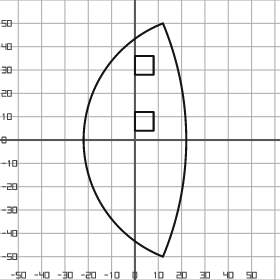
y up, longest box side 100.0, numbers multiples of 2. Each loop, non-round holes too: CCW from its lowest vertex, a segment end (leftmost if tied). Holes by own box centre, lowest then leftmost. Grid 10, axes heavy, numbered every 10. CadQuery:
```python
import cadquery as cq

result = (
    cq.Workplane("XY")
    .moveTo(12.0, -50.0)
    .threePointArc((22.0, 0.0), (12.0, 50.0))
    .threePointArc((-22.0, 0.0), (12.0, -50.0))
    .close()
    .moveTo(0.0, 4.0)
    .lineTo(8.0, 4.0)
    .lineTo(8.0, 12.0)
    .lineTo(0.0, 12.0)
    .close()
    .moveTo(0.0, 28.0)
    .lineTo(8.0, 28.0)
    .lineTo(8.0, 36.0)
    .lineTo(0.0, 36.0)
    .close()
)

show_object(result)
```